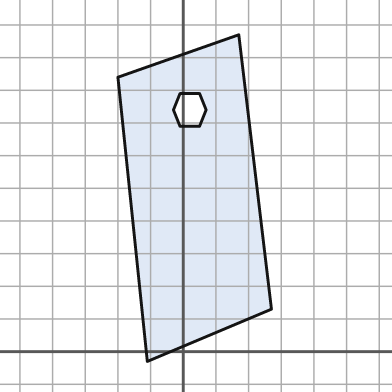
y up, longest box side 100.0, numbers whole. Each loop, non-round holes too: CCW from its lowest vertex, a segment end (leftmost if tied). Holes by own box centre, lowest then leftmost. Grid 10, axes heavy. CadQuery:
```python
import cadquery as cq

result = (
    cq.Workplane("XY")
    .moveTo(-11.0, -3.0)
    .lineTo(27.0, 13.0)
    .lineTo(17.0, 97.0)
    .lineTo(-20.0, 84.0)
    .close()
    .moveTo(-1.0, 69.0)
    .lineTo(5.0, 69.0)
    .lineTo(7.0, 74.0)
    .lineTo(5.0, 79.0)
    .lineTo(-1.0, 79.0)
    .lineTo(-3.0, 74.0)
    .close()
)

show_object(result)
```